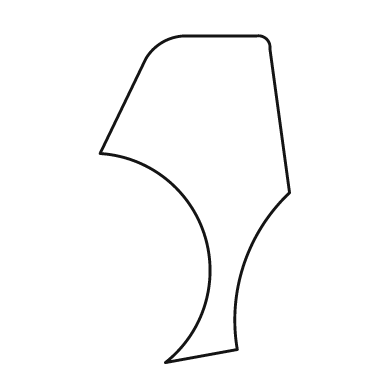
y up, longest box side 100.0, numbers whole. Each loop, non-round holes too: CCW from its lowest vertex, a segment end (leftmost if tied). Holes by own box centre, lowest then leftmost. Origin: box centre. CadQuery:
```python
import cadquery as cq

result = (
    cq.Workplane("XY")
    .moveTo(-9.0, -50.0)
    .lineTo(13.0, -46.0)
    .threePointArc((15.0, -20.0), (29.0, 2.0))
    .lineTo(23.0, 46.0)
    .threePointArc((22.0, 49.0), (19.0, 50.0))
    .lineTo(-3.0, 50.0)
    .threePointArc((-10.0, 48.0), (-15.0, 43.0))
    .lineTo(-29.0, 14.0)
    .threePointArc((3.0, -11.0), (-9.0, -50.0))
    .close()
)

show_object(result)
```